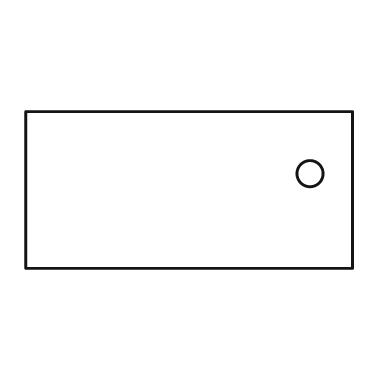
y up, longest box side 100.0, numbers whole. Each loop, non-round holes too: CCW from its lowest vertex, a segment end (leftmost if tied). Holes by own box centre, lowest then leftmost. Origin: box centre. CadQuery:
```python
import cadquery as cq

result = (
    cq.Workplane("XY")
    .moveTo(-50.0, -24.0)
    .lineTo(50.0, -24.0)
    .lineTo(50.0, 24.0)
    .lineTo(-50.0, 24.0)
    .close()
    .moveTo(37.0, 5.0)
    .circle(4.0)
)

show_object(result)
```